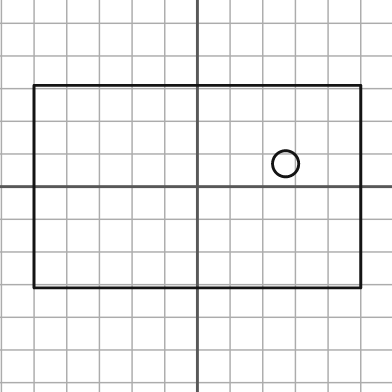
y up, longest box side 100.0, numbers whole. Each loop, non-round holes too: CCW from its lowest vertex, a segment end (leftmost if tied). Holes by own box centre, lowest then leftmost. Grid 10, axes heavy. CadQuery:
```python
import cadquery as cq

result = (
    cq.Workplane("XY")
    .moveTo(-50.0, -31.0)
    .lineTo(50.0, -31.0)
    .lineTo(50.0, 31.0)
    .lineTo(-50.0, 31.0)
    .close()
    .moveTo(27.0, 7.0)
    .circle(4.0)
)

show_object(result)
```